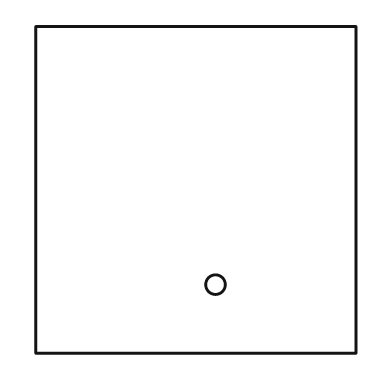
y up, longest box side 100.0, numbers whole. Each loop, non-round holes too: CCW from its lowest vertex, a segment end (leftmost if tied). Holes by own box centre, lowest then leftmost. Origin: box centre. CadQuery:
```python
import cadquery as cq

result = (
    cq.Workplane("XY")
    .moveTo(-49.0, -50.0)
    .lineTo(49.0, -50.0)
    .lineTo(49.0, 50.0)
    .lineTo(-49.0, 50.0)
    .close()
    .moveTo(6.0, -29.0)
    .circle(3.0)
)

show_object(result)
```